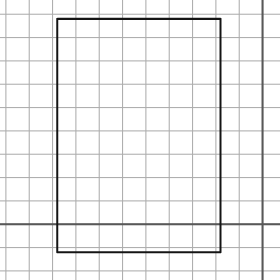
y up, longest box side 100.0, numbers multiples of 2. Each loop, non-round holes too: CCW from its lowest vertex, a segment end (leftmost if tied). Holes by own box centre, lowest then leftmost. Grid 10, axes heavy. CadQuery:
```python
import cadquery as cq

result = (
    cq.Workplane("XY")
    .moveTo(-88.0, -12.0)
    .lineTo(-18.0, -12.0)
    .lineTo(-18.0, 88.0)
    .lineTo(-88.0, 88.0)
    .close()
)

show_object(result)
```